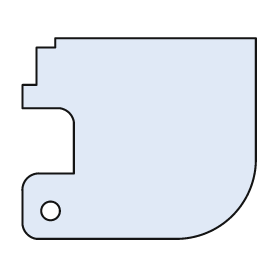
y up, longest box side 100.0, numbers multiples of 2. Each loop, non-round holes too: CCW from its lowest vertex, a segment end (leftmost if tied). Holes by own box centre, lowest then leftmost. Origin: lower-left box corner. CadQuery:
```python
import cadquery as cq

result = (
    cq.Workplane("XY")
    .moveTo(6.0, 0.0)
    .lineTo(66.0, 0.0)
    .threePointArc((90.0, 10.0), (100.0, 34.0))
    .lineTo(100.0, 86.0)
    .lineTo(14.0, 86.0)
    .lineTo(14.0, 82.0)
    .lineTo(6.0, 82.0)
    .lineTo(6.0, 66.0)
    .lineTo(0.0, 66.0)
    .lineTo(0.0, 56.0)
    .lineTo(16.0, 56.0)
    .threePointArc((20.0, 54.0), (22.0, 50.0))
    .lineTo(22.0, 28.0)
    .lineTo(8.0, 28.0)
    .threePointArc((2.0, 26.0), (0.0, 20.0))
    .lineTo(0.0, 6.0)
    .threePointArc((2.0, 2.0), (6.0, 0.0))
    .close()
    .moveTo(12.0, 12.0)
    .circle(4.0)
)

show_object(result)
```